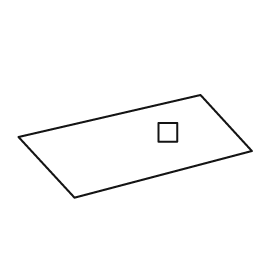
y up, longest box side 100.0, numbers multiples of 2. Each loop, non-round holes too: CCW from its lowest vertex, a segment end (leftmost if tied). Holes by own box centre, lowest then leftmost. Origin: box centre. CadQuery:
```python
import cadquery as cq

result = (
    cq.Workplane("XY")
    .moveTo(-26.0, -22.0)
    .lineTo(50.0, -2.0)
    .lineTo(28.0, 22.0)
    .lineTo(-50.0, 4.0)
    .close()
    .moveTo(10.0, 2.0)
    .lineTo(18.0, 2.0)
    .lineTo(18.0, 10.0)
    .lineTo(10.0, 10.0)
    .close()
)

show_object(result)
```